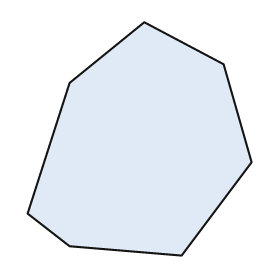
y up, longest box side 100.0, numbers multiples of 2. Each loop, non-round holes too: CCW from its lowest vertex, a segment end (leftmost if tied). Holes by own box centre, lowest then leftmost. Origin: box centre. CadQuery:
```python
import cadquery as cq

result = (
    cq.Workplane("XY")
    .moveTo(18.0, -50.0)
    .lineTo(48.0, -10.0)
    .lineTo(36.0, 32.0)
    .lineTo(2.0, 50.0)
    .lineTo(-30.0, 24.0)
    .lineTo(-48.0, -32.0)
    .lineTo(-30.0, -46.0)
    .close()
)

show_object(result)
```